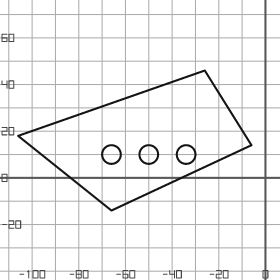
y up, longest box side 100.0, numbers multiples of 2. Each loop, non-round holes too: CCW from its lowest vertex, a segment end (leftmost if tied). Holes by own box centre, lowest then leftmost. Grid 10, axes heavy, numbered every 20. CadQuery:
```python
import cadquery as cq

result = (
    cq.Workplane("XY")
    .moveTo(-66.0, -14.0)
    .lineTo(-6.0, 14.0)
    .lineTo(-26.0, 46.0)
    .lineTo(-106.0, 18.0)
    .close()
    .moveTo(-66.0, 10.0)
    .circle(4.0)
    .moveTo(-50.0, 10.0)
    .circle(4.0)
    .moveTo(-34.0, 10.0)
    .circle(4.0)
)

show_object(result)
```